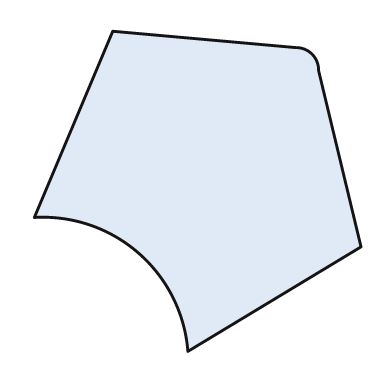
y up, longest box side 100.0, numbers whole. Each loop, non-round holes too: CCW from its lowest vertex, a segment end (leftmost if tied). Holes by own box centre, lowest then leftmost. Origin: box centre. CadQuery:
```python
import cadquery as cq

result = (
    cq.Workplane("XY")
    .moveTo(-3.0, -49.0)
    .lineTo(50.0, -17.0)
    .lineTo(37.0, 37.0)
    .threePointArc((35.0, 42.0), (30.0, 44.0))
    .lineTo(-26.0, 49.0)
    .lineTo(-50.0, -8.0)
    .threePointArc((-18.0, -19.0), (-3.0, -49.0))
    .close()
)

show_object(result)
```